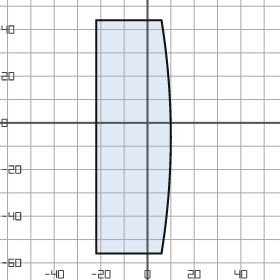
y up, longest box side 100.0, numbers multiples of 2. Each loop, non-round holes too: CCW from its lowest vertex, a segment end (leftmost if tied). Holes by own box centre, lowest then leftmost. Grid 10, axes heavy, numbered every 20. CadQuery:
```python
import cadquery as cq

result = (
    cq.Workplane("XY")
    .moveTo(-22.0, -56.0)
    .lineTo(6.0, -56.0)
    .threePointArc((10.0, -6.0), (6.0, 44.0))
    .lineTo(-22.0, 44.0)
    .close()
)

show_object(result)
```